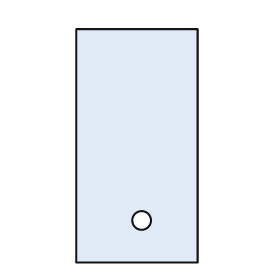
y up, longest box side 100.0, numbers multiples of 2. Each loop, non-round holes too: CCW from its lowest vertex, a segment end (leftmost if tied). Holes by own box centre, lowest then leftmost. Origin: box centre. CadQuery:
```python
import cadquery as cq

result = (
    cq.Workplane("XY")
    .moveTo(-26.0, -50.0)
    .lineTo(26.0, -50.0)
    .lineTo(26.0, 50.0)
    .lineTo(-26.0, 50.0)
    .close()
    .moveTo(2.0, -32.0)
    .circle(4.0)
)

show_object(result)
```